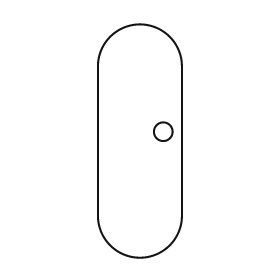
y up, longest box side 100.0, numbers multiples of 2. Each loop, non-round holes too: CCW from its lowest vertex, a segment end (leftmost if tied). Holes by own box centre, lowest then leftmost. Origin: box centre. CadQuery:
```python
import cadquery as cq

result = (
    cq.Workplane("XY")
    .moveTo(-18.0, -32.0)
    .threePointArc((0.0, -50.0), (18.0, -32.0))
    .lineTo(18.0, 32.0)
    .threePointArc((0.0, 50.0), (-18.0, 32.0))
    .close()
    .moveTo(10.0, 4.0)
    .circle(4.0)
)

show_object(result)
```